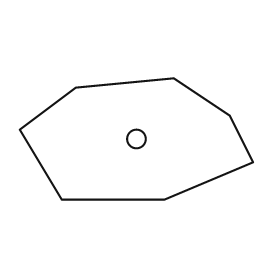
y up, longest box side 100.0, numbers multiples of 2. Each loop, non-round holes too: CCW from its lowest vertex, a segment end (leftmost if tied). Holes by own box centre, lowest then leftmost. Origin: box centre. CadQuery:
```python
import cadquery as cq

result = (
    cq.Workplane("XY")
    .moveTo(-32.0, -26.0)
    .lineTo(12.0, -26.0)
    .lineTo(50.0, -10.0)
    .lineTo(40.0, 10.0)
    .lineTo(16.0, 26.0)
    .lineTo(-26.0, 22.0)
    .lineTo(-50.0, 4.0)
    .close()
    .moveTo(0.0, 0.0)
    .circle(4.0)
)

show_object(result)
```